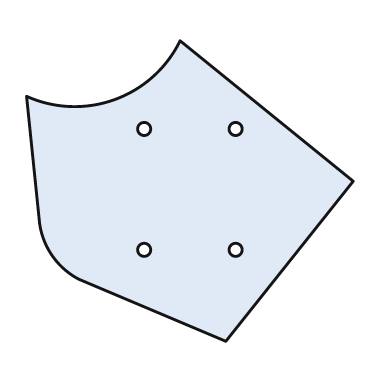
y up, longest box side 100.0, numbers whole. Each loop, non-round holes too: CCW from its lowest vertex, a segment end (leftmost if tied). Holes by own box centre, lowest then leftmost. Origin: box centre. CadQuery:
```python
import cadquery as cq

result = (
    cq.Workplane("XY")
    .moveTo(11.0, -46.0)
    .lineTo(50.0, 3.0)
    .lineTo(-3.0, 46.0)
    .threePointArc((-23.0, 28.0), (-50.0, 29.0))
    .lineTo(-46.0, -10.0)
    .threePointArc((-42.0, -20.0), (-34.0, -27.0))
    .close()
    .moveTo(-14.0, -18.0)
    .circle(2.0)
    .moveTo(14.0, -18.0)
    .circle(2.0)
    .moveTo(-14.0, 19.0)
    .circle(2.0)
    .moveTo(14.0, 19.0)
    .circle(2.0)
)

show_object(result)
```